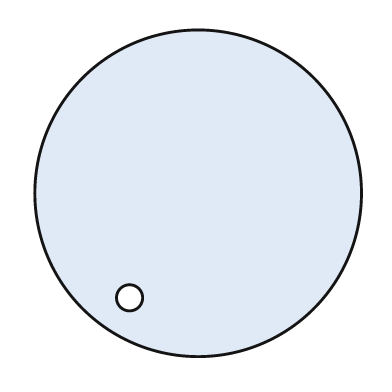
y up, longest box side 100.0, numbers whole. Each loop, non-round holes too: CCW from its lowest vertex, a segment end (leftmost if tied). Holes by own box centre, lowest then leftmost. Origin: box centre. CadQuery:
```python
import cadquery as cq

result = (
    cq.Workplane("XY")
    .moveTo(0.0, 0.0)
    .circle(50.0)
    .moveTo(-21.0, -32.0)
    .circle(4.0)
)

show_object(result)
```